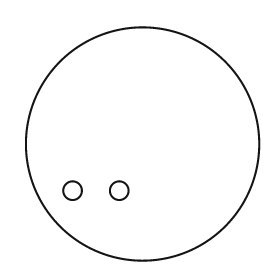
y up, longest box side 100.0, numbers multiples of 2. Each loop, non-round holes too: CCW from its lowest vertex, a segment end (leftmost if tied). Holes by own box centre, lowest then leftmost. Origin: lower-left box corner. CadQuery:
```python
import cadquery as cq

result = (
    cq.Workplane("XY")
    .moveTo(50.0, 50.0)
    .circle(50.0)
    .moveTo(20.0, 30.0)
    .circle(4.0)
    .moveTo(40.0, 30.0)
    .circle(4.0)
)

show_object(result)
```